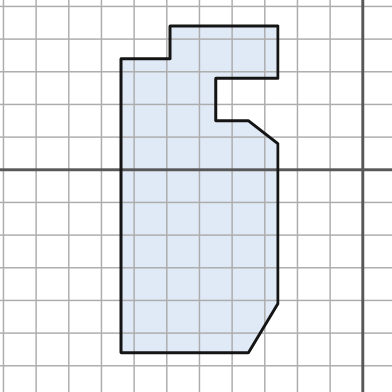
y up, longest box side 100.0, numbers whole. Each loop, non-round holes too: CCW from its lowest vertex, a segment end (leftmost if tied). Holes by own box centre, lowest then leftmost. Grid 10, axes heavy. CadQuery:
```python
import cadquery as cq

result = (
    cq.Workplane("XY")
    .moveTo(-74.0, -56.0)
    .lineTo(-35.0, -56.0)
    .lineTo(-26.0, -41.0)
    .lineTo(-26.0, 8.0)
    .lineTo(-35.0, 15.0)
    .lineTo(-45.0, 15.0)
    .lineTo(-45.0, 28.0)
    .lineTo(-26.0, 28.0)
    .lineTo(-26.0, 44.0)
    .lineTo(-59.0, 44.0)
    .lineTo(-59.0, 34.0)
    .lineTo(-74.0, 34.0)
    .close()
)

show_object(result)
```